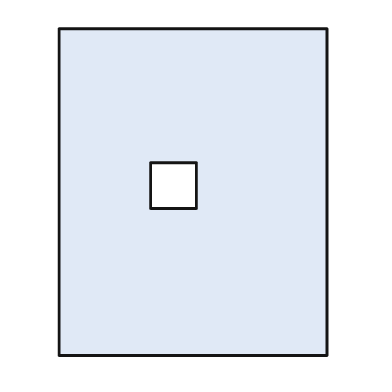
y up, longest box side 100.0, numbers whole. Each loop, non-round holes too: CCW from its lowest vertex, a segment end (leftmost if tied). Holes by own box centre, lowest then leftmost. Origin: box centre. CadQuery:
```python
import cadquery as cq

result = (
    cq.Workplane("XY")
    .moveTo(-41.0, -50.0)
    .lineTo(41.0, -50.0)
    .lineTo(41.0, 50.0)
    .lineTo(-41.0, 50.0)
    .close()
    .moveTo(-13.0, -5.0)
    .lineTo(1.0, -5.0)
    .lineTo(1.0, 9.0)
    .lineTo(-13.0, 9.0)
    .close()
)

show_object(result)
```